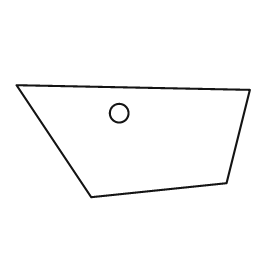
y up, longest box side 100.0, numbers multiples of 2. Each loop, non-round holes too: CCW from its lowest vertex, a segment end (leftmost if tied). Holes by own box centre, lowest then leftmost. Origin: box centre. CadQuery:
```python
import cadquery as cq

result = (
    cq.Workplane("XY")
    .moveTo(-18.0, -24.0)
    .lineTo(40.0, -18.0)
    .lineTo(50.0, 22.0)
    .lineTo(-50.0, 24.0)
    .close()
    .moveTo(-6.0, 12.0)
    .circle(4.0)
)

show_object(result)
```